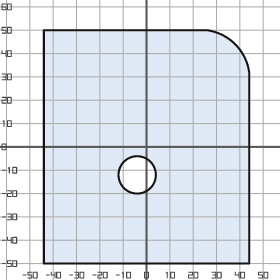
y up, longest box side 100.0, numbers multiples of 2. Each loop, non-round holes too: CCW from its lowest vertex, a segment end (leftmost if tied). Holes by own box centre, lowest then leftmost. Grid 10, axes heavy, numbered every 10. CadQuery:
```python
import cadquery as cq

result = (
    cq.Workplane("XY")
    .moveTo(-44.0, -50.0)
    .lineTo(44.0, -50.0)
    .lineTo(44.0, 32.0)
    .threePointArc((38.0, 44.0), (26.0, 50.0))
    .lineTo(-44.0, 50.0)
    .close()
    .moveTo(-4.0, -12.0)
    .circle(8.0)
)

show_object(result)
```